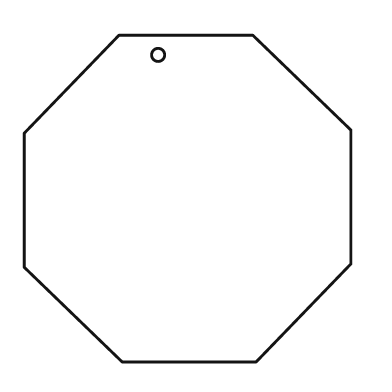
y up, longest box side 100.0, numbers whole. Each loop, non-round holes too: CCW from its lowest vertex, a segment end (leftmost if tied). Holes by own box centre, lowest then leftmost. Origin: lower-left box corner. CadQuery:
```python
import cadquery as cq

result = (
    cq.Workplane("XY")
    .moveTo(30.0, 0.0)
    .lineTo(71.0, 0.0)
    .lineTo(100.0, 30.0)
    .lineTo(100.0, 71.0)
    .lineTo(70.0, 100.0)
    .lineTo(29.0, 100.0)
    .lineTo(0.0, 70.0)
    .lineTo(0.0, 29.0)
    .close()
    .moveTo(41.0, 94.0)
    .circle(2.0)
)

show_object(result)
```